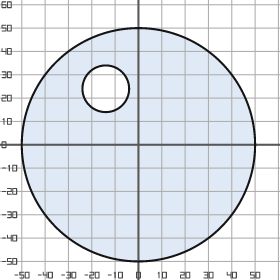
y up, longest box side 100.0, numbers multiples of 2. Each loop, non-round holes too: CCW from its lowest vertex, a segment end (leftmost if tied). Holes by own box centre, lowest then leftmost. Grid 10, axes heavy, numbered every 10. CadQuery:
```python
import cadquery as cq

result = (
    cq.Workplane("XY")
    .moveTo(0.0, 0.0)
    .circle(50.0)
    .moveTo(-14.0, 24.0)
    .circle(10.0)
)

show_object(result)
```